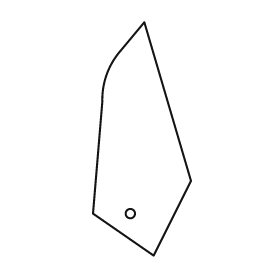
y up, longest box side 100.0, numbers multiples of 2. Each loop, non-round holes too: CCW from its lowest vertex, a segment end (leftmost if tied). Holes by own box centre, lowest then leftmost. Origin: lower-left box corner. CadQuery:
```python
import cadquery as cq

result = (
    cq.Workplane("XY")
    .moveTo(26.0, 0.0)
    .lineTo(42.0, 32.0)
    .lineTo(22.0, 100.0)
    .lineTo(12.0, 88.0)
    .threePointArc((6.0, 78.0), (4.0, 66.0))
    .lineTo(0.0, 18.0)
    .close()
    .moveTo(16.0, 18.0)
    .circle(2.0)
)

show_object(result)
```